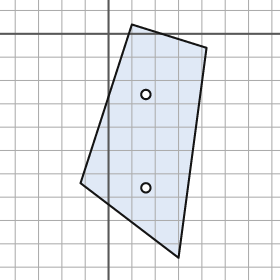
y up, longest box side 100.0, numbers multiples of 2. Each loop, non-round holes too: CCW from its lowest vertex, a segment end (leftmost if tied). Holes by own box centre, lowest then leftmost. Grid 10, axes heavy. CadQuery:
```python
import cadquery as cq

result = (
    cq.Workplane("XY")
    .moveTo(30.0, -96.0)
    .lineTo(42.0, -6.0)
    .lineTo(10.0, 4.0)
    .lineTo(-12.0, -64.0)
    .close()
    .moveTo(16.0, -66.0)
    .circle(2.0)
    .moveTo(16.0, -26.0)
    .circle(2.0)
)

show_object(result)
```